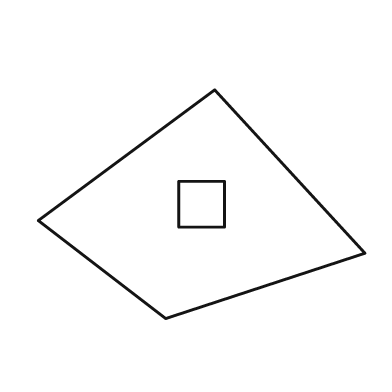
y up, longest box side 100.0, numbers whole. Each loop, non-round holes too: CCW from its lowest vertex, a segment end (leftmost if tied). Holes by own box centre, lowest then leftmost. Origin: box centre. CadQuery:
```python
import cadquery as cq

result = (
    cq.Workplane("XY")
    .moveTo(-11.0, -35.0)
    .lineTo(50.0, -15.0)
    .lineTo(4.0, 35.0)
    .lineTo(-50.0, -5.0)
    .close()
    .moveTo(-7.0, -7.0)
    .lineTo(7.0, -7.0)
    .lineTo(7.0, 7.0)
    .lineTo(-7.0, 7.0)
    .close()
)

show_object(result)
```